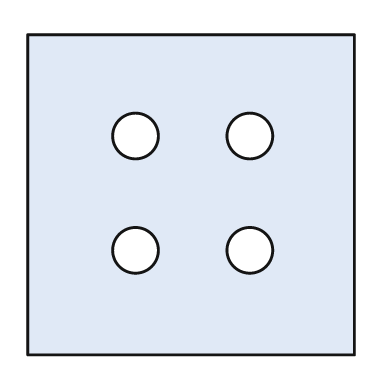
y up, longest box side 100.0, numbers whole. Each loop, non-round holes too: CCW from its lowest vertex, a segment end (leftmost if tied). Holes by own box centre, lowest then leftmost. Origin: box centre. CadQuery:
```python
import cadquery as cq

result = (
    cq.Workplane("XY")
    .moveTo(-50.0, -49.0)
    .lineTo(50.0, -49.0)
    .lineTo(50.0, 49.0)
    .lineTo(-50.0, 49.0)
    .close()
    .moveTo(-17.0, -17.0)
    .circle(7.0)
    .moveTo(18.0, -17.0)
    .circle(7.0)
    .moveTo(-17.0, 18.0)
    .circle(7.0)
    .moveTo(18.0, 18.0)
    .circle(7.0)
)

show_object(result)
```